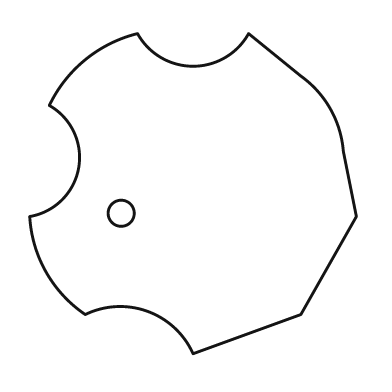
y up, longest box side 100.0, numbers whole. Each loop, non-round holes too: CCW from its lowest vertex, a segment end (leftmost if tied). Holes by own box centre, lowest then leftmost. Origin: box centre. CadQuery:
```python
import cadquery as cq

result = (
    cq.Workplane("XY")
    .moveTo(0.0, -49.0)
    .lineTo(33.0, -37.0)
    .lineTo(50.0, -7.0)
    .lineTo(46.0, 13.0)
    .threePointArc((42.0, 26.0), (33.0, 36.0))
    .lineTo(17.0, 49.0)
    .threePointArc((0.0, 39.0), (-17.0, 49.0))
    .threePointArc((-33.0, 41.0), (-44.0, 27.0))
    .threePointArc((-35.0, 8.0), (-50.0, -7.0))
    .threePointArc((-45.0, -24.0), (-33.0, -37.0))
    .threePointArc((-14.0, -36.0), (0.0, -49.0))
    .close()
    .moveTo(-22.0, -6.0)
    .circle(4.0)
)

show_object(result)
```